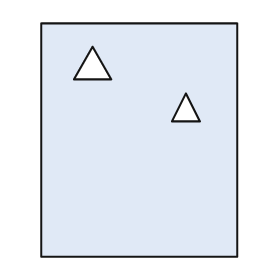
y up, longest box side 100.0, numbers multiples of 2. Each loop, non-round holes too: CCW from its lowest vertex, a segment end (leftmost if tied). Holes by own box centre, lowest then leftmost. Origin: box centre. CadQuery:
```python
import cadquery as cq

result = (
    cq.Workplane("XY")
    .moveTo(-42.0, -50.0)
    .lineTo(42.0, -50.0)
    .lineTo(42.0, 50.0)
    .lineTo(-42.0, 50.0)
    .close()
    .moveTo(14.0, 8.0)
    .lineTo(26.0, 8.0)
    .lineTo(20.0, 20.0)
    .close()
    .moveTo(-28.0, 26.0)
    .lineTo(-12.0, 26.0)
    .lineTo(-20.0, 40.0)
    .close()
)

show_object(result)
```